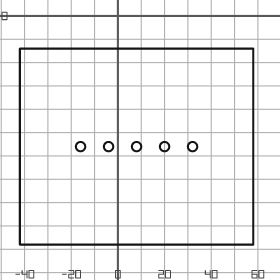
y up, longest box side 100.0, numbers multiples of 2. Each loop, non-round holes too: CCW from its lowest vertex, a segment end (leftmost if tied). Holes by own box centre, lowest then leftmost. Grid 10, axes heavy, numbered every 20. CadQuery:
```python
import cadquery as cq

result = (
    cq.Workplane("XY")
    .moveTo(-42.0, -98.0)
    .lineTo(58.0, -98.0)
    .lineTo(58.0, -14.0)
    .lineTo(-42.0, -14.0)
    .close()
    .moveTo(-16.0, -56.0)
    .circle(2.0)
    .moveTo(-4.0, -56.0)
    .circle(2.0)
    .moveTo(8.0, -56.0)
    .circle(2.0)
    .moveTo(20.0, -56.0)
    .circle(2.0)
    .moveTo(32.0, -56.0)
    .circle(2.0)
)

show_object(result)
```